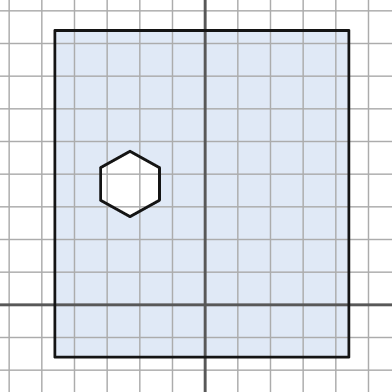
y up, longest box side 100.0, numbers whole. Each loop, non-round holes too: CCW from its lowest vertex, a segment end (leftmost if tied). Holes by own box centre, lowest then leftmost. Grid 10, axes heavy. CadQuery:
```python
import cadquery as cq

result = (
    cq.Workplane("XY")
    .moveTo(-46.0, -16.0)
    .lineTo(44.0, -16.0)
    .lineTo(44.0, 84.0)
    .lineTo(-46.0, 84.0)
    .close()
    .moveTo(-23.0, 27.0)
    .lineTo(-14.0, 32.0)
    .lineTo(-14.0, 42.0)
    .lineTo(-23.0, 47.0)
    .lineTo(-32.0, 42.0)
    .lineTo(-32.0, 32.0)
    .close()
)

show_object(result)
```